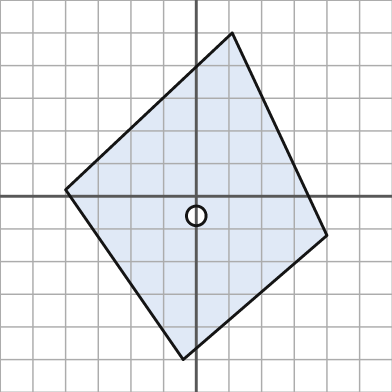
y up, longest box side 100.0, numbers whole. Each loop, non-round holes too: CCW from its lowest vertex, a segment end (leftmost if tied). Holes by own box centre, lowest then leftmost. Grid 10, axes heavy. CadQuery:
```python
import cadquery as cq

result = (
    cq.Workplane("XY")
    .moveTo(-4.0, -50.0)
    .lineTo(40.0, -12.0)
    .lineTo(11.0, 50.0)
    .lineTo(-40.0, 2.0)
    .close()
    .moveTo(0.0, -6.0)
    .circle(3.0)
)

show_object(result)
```